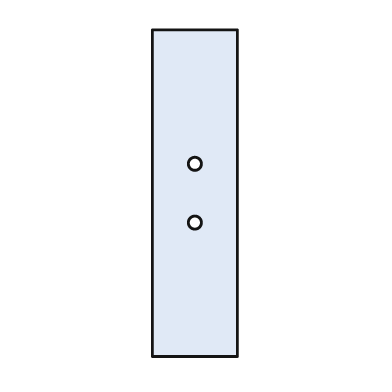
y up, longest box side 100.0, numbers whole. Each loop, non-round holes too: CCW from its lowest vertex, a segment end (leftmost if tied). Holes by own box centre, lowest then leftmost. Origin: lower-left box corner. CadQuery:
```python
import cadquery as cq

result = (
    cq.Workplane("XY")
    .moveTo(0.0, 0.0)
    .lineTo(26.0, 0.0)
    .lineTo(26.0, 100.0)
    .lineTo(0.0, 100.0)
    .close()
    .moveTo(13.0, 41.0)
    .circle(2.0)
    .moveTo(13.0, 59.0)
    .circle(2.0)
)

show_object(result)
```